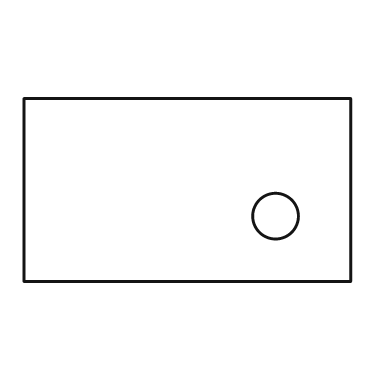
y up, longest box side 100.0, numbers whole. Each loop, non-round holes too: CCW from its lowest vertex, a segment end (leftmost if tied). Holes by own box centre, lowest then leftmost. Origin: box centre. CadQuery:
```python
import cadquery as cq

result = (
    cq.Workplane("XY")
    .moveTo(-50.0, -28.0)
    .lineTo(50.0, -28.0)
    .lineTo(50.0, 28.0)
    .lineTo(-50.0, 28.0)
    .close()
    .moveTo(27.0, -8.0)
    .circle(7.0)
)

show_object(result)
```